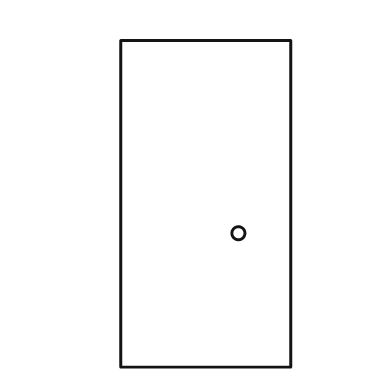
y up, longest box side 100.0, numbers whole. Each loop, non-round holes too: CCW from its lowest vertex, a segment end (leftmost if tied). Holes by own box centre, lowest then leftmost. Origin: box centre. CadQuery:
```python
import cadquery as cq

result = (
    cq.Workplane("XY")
    .moveTo(-26.0, -50.0)
    .lineTo(26.0, -50.0)
    .lineTo(26.0, 50.0)
    .lineTo(-26.0, 50.0)
    .close()
    .moveTo(10.0, -9.0)
    .circle(2.0)
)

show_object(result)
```